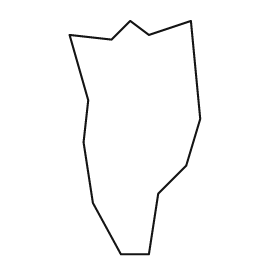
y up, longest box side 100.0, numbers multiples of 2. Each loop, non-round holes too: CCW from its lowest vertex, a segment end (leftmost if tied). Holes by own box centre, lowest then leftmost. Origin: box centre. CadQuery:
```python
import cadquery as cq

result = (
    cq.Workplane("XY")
    .moveTo(-6.0, -50.0)
    .lineTo(6.0, -50.0)
    .lineTo(10.0, -24.0)
    .lineTo(22.0, -12.0)
    .lineTo(28.0, 8.0)
    .lineTo(24.0, 50.0)
    .lineTo(6.0, 44.0)
    .lineTo(-2.0, 50.0)
    .lineTo(-10.0, 42.0)
    .lineTo(-28.0, 44.0)
    .lineTo(-20.0, 16.0)
    .lineTo(-22.0, -2.0)
    .lineTo(-18.0, -28.0)
    .close()
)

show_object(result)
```